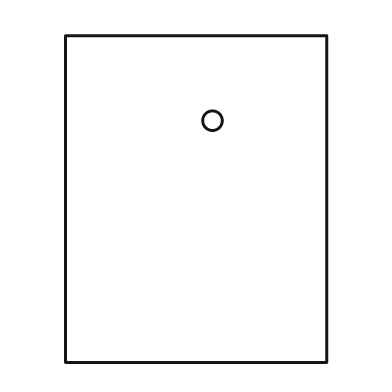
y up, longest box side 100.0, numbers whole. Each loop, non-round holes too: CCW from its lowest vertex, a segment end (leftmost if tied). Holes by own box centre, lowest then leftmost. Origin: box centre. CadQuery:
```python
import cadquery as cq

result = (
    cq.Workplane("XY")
    .moveTo(-40.0, -50.0)
    .lineTo(40.0, -50.0)
    .lineTo(40.0, 50.0)
    .lineTo(-40.0, 50.0)
    .close()
    .moveTo(5.0, 24.0)
    .circle(3.0)
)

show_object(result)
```